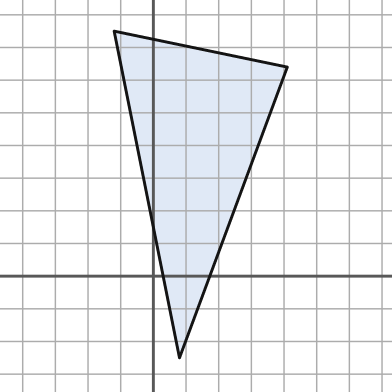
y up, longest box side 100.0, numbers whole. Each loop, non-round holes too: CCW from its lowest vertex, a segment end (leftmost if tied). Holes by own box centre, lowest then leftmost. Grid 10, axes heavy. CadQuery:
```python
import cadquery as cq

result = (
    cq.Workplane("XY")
    .moveTo(8.0, -25.0)
    .lineTo(41.0, 64.0)
    .lineTo(-12.0, 75.0)
    .close()
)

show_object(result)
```